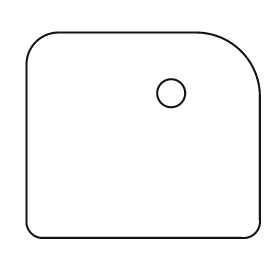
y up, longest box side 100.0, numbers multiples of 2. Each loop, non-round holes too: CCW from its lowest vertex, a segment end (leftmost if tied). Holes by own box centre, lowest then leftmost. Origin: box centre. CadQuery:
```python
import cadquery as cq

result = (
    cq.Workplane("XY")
    .moveTo(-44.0, -44.0)
    .lineTo(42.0, -44.0)
    .threePointArc((48.0, -42.0), (50.0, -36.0))
    .lineTo(50.0, 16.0)
    .threePointArc((42.0, 36.0), (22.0, 44.0))
    .lineTo(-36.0, 44.0)
    .threePointArc((-46.0, 40.0), (-50.0, 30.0))
    .lineTo(-50.0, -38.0)
    .threePointArc((-48.0, -42.0), (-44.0, -44.0))
    .close()
    .moveTo(12.0, 18.0)
    .circle(6.0)
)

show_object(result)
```